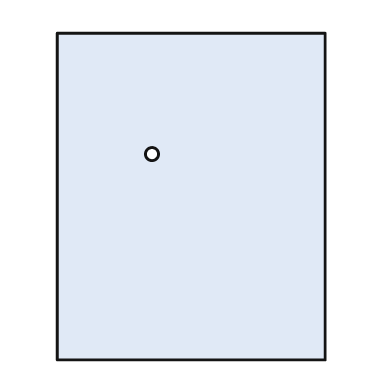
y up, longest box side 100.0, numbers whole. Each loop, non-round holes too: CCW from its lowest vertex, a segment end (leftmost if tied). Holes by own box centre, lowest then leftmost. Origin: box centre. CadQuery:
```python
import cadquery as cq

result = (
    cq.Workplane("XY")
    .moveTo(-41.0, -50.0)
    .lineTo(41.0, -50.0)
    .lineTo(41.0, 50.0)
    .lineTo(-41.0, 50.0)
    .close()
    .moveTo(-12.0, 13.0)
    .circle(2.0)
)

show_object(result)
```